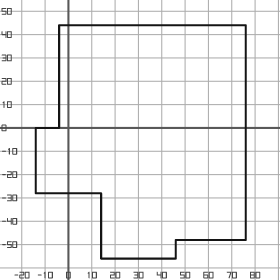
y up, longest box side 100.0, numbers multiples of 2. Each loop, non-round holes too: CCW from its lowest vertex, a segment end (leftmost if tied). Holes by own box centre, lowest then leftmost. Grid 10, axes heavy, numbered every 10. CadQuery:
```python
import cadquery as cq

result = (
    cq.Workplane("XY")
    .moveTo(14.0, -56.0)
    .lineTo(46.0, -56.0)
    .lineTo(46.0, -48.0)
    .lineTo(76.0, -48.0)
    .lineTo(76.0, 44.0)
    .lineTo(-4.0, 44.0)
    .lineTo(-4.0, 0.0)
    .lineTo(-14.0, 0.0)
    .lineTo(-14.0, -28.0)
    .lineTo(14.0, -28.0)
    .close()
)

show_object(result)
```